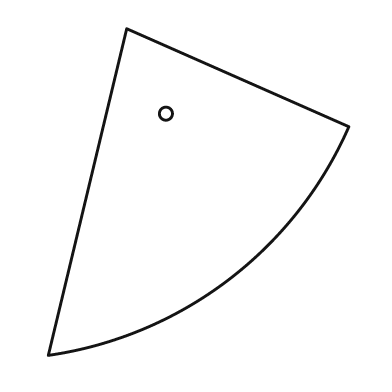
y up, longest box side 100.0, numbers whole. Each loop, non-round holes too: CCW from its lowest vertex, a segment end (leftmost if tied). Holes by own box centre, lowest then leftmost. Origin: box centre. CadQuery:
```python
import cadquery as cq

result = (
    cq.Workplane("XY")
    .moveTo(-46.0, -50.0)
    .threePointArc((9.0, -27.0), (46.0, 20.0))
    .lineTo(-22.0, 50.0)
    .close()
    .moveTo(-10.0, 24.0)
    .circle(2.0)
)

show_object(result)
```